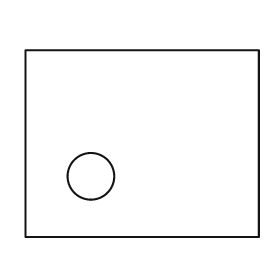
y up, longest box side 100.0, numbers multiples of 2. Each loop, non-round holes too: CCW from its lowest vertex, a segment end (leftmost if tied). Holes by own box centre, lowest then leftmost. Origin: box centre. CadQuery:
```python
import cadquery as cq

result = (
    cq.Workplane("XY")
    .moveTo(-50.0, -40.0)
    .lineTo(50.0, -40.0)
    .lineTo(50.0, 40.0)
    .lineTo(-50.0, 40.0)
    .close()
    .moveTo(-22.0, -14.0)
    .circle(10.0)
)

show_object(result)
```